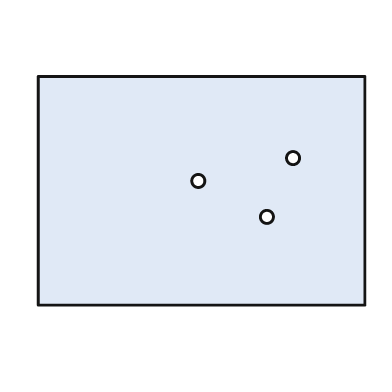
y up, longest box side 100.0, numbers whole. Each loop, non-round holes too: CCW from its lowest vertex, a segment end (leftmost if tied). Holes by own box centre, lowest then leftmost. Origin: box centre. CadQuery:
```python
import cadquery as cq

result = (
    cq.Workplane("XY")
    .moveTo(-50.0, -35.0)
    .lineTo(50.0, -35.0)
    .lineTo(50.0, 35.0)
    .lineTo(-50.0, 35.0)
    .close()
    .moveTo(20.0, -8.0)
    .circle(2.0)
    .moveTo(-1.0, 3.0)
    .circle(2.0)
    .moveTo(28.0, 10.0)
    .circle(2.0)
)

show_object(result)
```